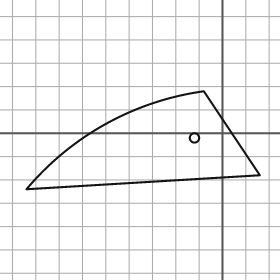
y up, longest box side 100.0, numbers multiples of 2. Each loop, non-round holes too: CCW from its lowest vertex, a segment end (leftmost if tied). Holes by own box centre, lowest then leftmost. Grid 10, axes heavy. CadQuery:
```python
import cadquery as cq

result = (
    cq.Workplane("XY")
    .moveTo(-84.0, -24.0)
    .lineTo(16.0, -18.0)
    .lineTo(-8.0, 18.0)
    .threePointArc((-50.0, 4.0), (-84.0, -24.0))
    .close()
    .moveTo(-12.0, -2.0)
    .circle(2.0)
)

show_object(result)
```